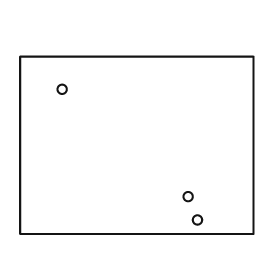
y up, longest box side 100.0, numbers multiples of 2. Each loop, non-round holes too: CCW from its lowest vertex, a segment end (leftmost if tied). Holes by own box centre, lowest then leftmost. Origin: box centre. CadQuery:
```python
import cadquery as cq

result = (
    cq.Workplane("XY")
    .moveTo(-50.0, -38.0)
    .lineTo(50.0, -38.0)
    .lineTo(50.0, 38.0)
    .lineTo(-50.0, 38.0)
    .close()
    .moveTo(26.0, -32.0)
    .circle(2.0)
    .moveTo(22.0, -22.0)
    .circle(2.0)
    .moveTo(-32.0, 24.0)
    .circle(2.0)
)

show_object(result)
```